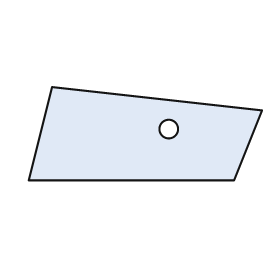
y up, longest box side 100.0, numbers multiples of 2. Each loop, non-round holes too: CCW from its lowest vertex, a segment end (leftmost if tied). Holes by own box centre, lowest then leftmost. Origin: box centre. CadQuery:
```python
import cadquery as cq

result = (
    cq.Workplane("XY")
    .moveTo(-50.0, -20.0)
    .lineTo(38.0, -20.0)
    .lineTo(50.0, 10.0)
    .lineTo(-40.0, 20.0)
    .close()
    .moveTo(10.0, 2.0)
    .circle(4.0)
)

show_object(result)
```